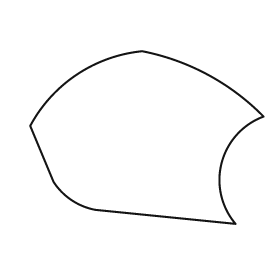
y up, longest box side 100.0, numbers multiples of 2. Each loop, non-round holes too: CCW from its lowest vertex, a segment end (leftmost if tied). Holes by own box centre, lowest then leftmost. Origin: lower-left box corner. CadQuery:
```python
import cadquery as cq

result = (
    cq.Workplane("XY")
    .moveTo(88.0, 0.0)
    .threePointArc((82.0, 26.0), (100.0, 46.0))
    .threePointArc((76.0, 64.0), (48.0, 74.0))
    .threePointArc((20.0, 64.0), (0.0, 42.0))
    .lineTo(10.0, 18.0)
    .threePointArc((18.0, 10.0), (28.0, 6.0))
    .close()
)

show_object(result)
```